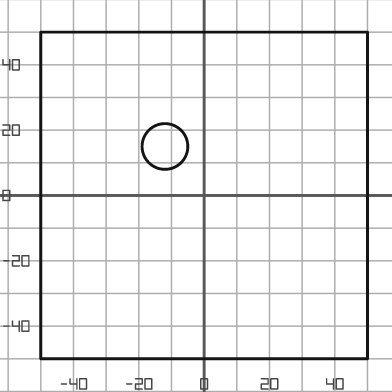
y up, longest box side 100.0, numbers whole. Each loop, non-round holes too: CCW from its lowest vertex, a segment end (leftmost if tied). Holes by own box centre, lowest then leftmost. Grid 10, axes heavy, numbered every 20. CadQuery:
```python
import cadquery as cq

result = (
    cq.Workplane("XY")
    .moveTo(-50.0, -50.0)
    .lineTo(50.0, -50.0)
    .lineTo(50.0, 50.0)
    .lineTo(-50.0, 50.0)
    .close()
    .moveTo(-12.0, 15.0)
    .circle(7.0)
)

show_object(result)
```